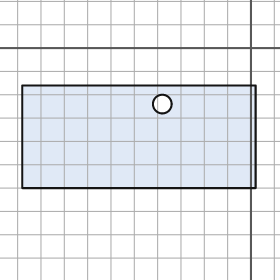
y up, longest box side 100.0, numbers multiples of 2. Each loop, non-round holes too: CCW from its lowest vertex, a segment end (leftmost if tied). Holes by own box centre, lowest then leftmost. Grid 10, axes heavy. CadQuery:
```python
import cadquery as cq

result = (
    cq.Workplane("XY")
    .moveTo(-98.0, -60.0)
    .lineTo(2.0, -60.0)
    .lineTo(2.0, -16.0)
    .lineTo(-98.0, -16.0)
    .close()
    .moveTo(-38.0, -24.0)
    .circle(4.0)
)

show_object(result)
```